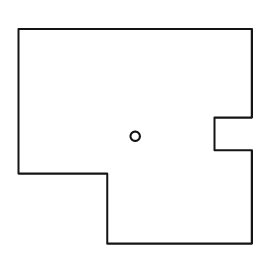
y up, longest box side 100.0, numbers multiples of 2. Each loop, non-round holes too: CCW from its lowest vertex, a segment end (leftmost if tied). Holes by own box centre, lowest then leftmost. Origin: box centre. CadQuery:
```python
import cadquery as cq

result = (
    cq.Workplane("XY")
    .moveTo(-12.0, -46.0)
    .lineTo(50.0, -46.0)
    .lineTo(50.0, -6.0)
    .lineTo(34.0, -6.0)
    .lineTo(34.0, 8.0)
    .lineTo(50.0, 8.0)
    .lineTo(50.0, 46.0)
    .lineTo(-50.0, 46.0)
    .lineTo(-50.0, -16.0)
    .lineTo(-12.0, -16.0)
    .close()
    .moveTo(0.0, 0.0)
    .circle(2.0)
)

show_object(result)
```